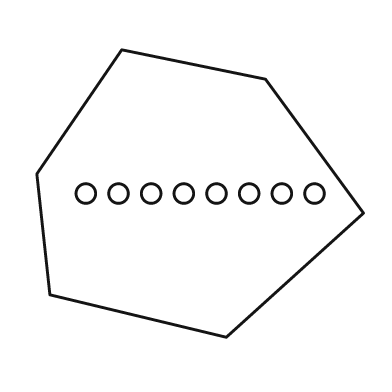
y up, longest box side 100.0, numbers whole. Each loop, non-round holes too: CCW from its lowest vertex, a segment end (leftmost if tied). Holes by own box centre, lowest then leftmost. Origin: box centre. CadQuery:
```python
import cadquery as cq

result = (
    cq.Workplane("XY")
    .moveTo(8.0, -44.0)
    .lineTo(50.0, -6.0)
    .lineTo(20.0, 35.0)
    .lineTo(-24.0, 44.0)
    .lineTo(-50.0, 6.0)
    .lineTo(-46.0, -31.0)
    .close()
    .moveTo(-35.0, 0.0)
    .circle(3.0)
    .moveTo(-25.0, 0.0)
    .circle(3.0)
    .moveTo(-15.0, 0.0)
    .circle(3.0)
    .moveTo(-5.0, 0.0)
    .circle(3.0)
    .moveTo(5.0, 0.0)
    .circle(3.0)
    .moveTo(15.0, 0.0)
    .circle(3.0)
    .moveTo(25.0, 0.0)
    .circle(3.0)
    .moveTo(35.0, 0.0)
    .circle(3.0)
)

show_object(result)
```